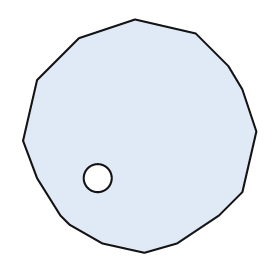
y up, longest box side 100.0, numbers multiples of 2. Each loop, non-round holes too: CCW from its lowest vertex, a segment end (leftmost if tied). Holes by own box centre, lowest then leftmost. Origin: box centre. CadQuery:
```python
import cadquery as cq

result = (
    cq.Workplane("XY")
    .moveTo(2.0, -50.0)
    .lineTo(16.0, -46.0)
    .lineTo(34.0, -34.0)
    .lineTo(44.0, -24.0)
    .lineTo(50.0, 2.0)
    .lineTo(44.0, 20.0)
    .lineTo(38.0, 30.0)
    .lineTo(24.0, 44.0)
    .lineTo(-2.0, 50.0)
    .lineTo(-26.0, 42.0)
    .lineTo(-44.0, 24.0)
    .lineTo(-50.0, -2.0)
    .lineTo(-44.0, -18.0)
    .lineTo(-34.0, -34.0)
    .lineTo(-30.0, -38.0)
    .lineTo(-16.0, -46.0)
    .close()
    .moveTo(-18.0, -18.0)
    .circle(6.0)
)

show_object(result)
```